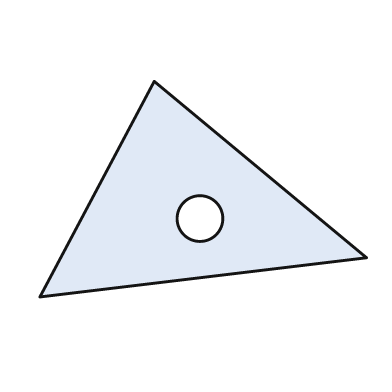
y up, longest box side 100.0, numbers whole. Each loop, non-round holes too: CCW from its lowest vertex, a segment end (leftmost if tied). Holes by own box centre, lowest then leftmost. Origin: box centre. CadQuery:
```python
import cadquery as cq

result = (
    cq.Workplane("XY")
    .moveTo(-50.0, -33.0)
    .lineTo(50.0, -21.0)
    .lineTo(-15.0, 33.0)
    .close()
    .moveTo(-1.0, -9.0)
    .circle(7.0)
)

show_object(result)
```